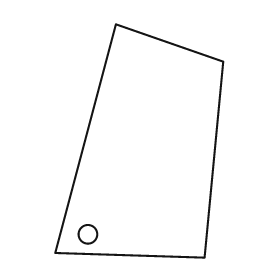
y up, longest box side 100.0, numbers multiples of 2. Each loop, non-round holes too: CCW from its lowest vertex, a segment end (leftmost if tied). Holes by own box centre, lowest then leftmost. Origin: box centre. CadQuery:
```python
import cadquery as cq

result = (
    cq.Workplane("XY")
    .moveTo(28.0, -50.0)
    .lineTo(36.0, 34.0)
    .lineTo(-10.0, 50.0)
    .lineTo(-36.0, -48.0)
    .close()
    .moveTo(-22.0, -40.0)
    .circle(4.0)
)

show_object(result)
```